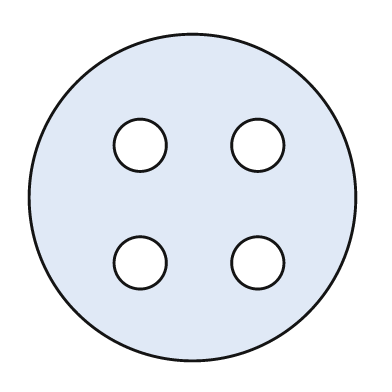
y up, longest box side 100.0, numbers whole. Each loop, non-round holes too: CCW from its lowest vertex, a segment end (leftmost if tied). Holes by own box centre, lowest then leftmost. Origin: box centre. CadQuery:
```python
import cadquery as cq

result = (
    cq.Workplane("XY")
    .moveTo(0.0, 0.0)
    .circle(50.0)
    .moveTo(-16.0, -20.0)
    .circle(8.0)
    .moveTo(20.0, -20.0)
    .circle(8.0)
    .moveTo(-16.0, 16.0)
    .circle(8.0)
    .moveTo(20.0, 16.0)
    .circle(8.0)
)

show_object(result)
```